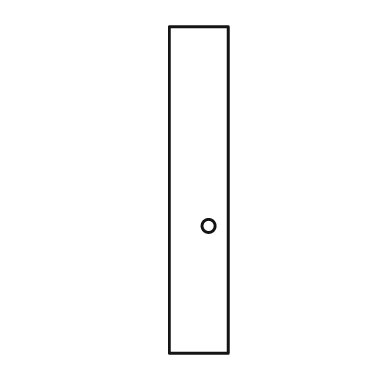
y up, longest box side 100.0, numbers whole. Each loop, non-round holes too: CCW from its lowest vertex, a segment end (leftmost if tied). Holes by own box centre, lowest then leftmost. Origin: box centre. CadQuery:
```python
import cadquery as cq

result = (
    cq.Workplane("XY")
    .moveTo(-9.0, -50.0)
    .lineTo(9.0, -50.0)
    .lineTo(9.0, 50.0)
    .lineTo(-9.0, 50.0)
    .close()
    .moveTo(3.0, -11.0)
    .circle(2.0)
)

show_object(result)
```